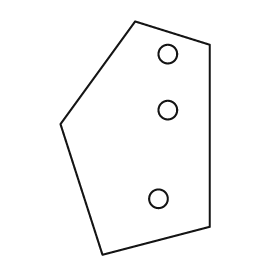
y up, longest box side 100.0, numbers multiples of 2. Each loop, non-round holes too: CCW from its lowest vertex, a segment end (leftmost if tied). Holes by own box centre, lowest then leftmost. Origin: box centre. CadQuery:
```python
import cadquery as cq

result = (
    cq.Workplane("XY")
    .moveTo(-14.0, -50.0)
    .lineTo(32.0, -38.0)
    .lineTo(32.0, 40.0)
    .lineTo(0.0, 50.0)
    .lineTo(-32.0, 6.0)
    .close()
    .moveTo(10.0, -26.0)
    .circle(4.0)
    .moveTo(14.0, 12.0)
    .circle(4.0)
    .moveTo(14.0, 36.0)
    .circle(4.0)
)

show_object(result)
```